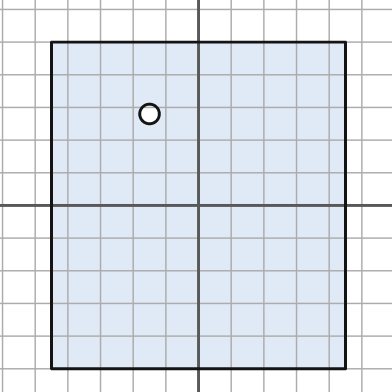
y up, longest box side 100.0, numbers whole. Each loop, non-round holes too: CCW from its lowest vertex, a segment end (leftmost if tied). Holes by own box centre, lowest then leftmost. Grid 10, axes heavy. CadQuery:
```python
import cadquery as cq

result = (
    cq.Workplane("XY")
    .moveTo(-45.0, -50.0)
    .lineTo(45.0, -50.0)
    .lineTo(45.0, 50.0)
    .lineTo(-45.0, 50.0)
    .close()
    .moveTo(-15.0, 28.0)
    .circle(3.0)
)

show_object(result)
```